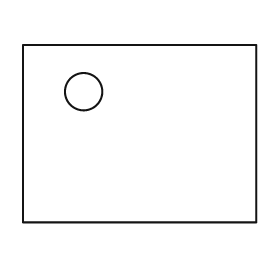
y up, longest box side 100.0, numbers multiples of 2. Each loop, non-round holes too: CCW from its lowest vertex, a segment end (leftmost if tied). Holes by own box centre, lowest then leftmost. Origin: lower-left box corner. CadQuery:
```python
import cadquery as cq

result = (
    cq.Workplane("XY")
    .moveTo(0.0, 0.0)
    .lineTo(100.0, 0.0)
    .lineTo(100.0, 76.0)
    .lineTo(0.0, 76.0)
    .close()
    .moveTo(26.0, 56.0)
    .circle(8.0)
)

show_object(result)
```